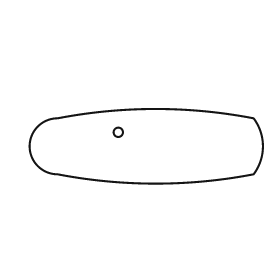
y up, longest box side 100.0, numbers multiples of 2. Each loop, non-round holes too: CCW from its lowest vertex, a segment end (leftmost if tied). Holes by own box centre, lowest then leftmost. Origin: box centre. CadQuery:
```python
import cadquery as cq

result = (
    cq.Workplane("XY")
    .moveTo(-38.0, -12.0)
    .threePointArc((4.0, -16.0), (46.0, -12.0))
    .threePointArc((50.0, 0.0), (46.0, 12.0))
    .threePointArc((4.0, 16.0), (-38.0, 12.0))
    .threePointArc((-50.0, 0.0), (-38.0, -12.0))
    .close()
    .moveTo(-12.0, 6.0)
    .circle(2.0)
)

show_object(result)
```